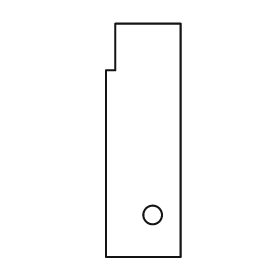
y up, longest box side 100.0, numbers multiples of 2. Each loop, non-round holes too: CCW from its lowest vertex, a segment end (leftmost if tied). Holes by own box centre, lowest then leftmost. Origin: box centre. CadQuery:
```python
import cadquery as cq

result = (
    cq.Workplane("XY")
    .moveTo(-16.0, -50.0)
    .lineTo(16.0, -50.0)
    .lineTo(16.0, 50.0)
    .lineTo(-12.0, 50.0)
    .lineTo(-12.0, 30.0)
    .lineTo(-16.0, 30.0)
    .close()
    .moveTo(4.0, -32.0)
    .circle(4.0)
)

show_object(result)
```